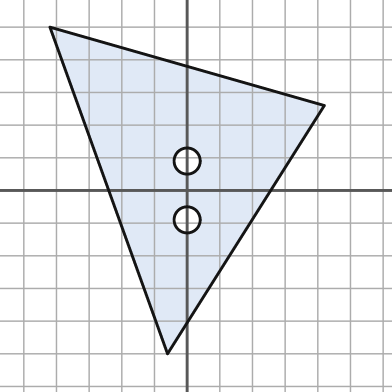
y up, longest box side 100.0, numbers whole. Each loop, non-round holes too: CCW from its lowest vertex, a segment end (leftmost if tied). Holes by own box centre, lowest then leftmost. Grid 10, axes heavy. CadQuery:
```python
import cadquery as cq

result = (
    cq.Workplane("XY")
    .moveTo(-6.0, -50.0)
    .lineTo(42.0, 26.0)
    .lineTo(-42.0, 50.0)
    .close()
    .moveTo(0.0, -9.0)
    .circle(4.0)
    .moveTo(0.0, 9.0)
    .circle(4.0)
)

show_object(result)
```